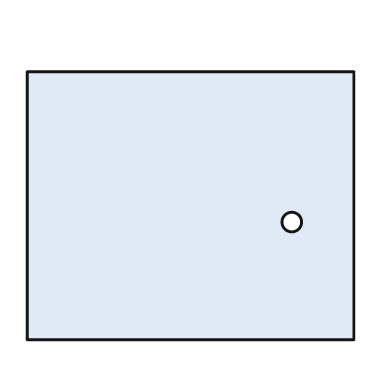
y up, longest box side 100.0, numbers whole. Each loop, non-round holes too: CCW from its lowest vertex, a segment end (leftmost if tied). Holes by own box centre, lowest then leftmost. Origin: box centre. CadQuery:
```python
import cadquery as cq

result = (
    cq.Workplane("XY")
    .moveTo(-50.0, -41.0)
    .lineTo(50.0, -41.0)
    .lineTo(50.0, 41.0)
    .lineTo(-50.0, 41.0)
    .close()
    .moveTo(31.0, -5.0)
    .circle(3.0)
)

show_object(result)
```